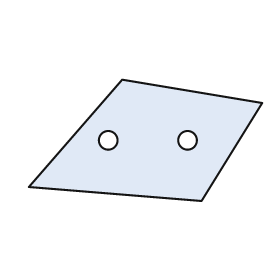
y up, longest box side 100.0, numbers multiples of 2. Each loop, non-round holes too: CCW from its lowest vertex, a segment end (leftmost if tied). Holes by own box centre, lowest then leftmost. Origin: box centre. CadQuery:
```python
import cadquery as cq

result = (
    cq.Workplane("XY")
    .moveTo(24.0, -26.0)
    .lineTo(50.0, 16.0)
    .lineTo(-10.0, 26.0)
    .lineTo(-50.0, -20.0)
    .close()
    .moveTo(-16.0, 0.0)
    .circle(4.0)
    .moveTo(18.0, 0.0)
    .circle(4.0)
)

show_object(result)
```